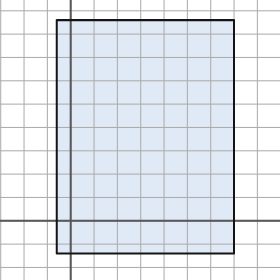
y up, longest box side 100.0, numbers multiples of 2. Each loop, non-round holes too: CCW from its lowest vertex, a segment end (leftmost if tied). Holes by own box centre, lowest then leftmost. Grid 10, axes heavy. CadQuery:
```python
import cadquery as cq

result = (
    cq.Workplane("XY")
    .moveTo(-6.0, -14.0)
    .lineTo(70.0, -14.0)
    .lineTo(70.0, 86.0)
    .lineTo(-6.0, 86.0)
    .close()
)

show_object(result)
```